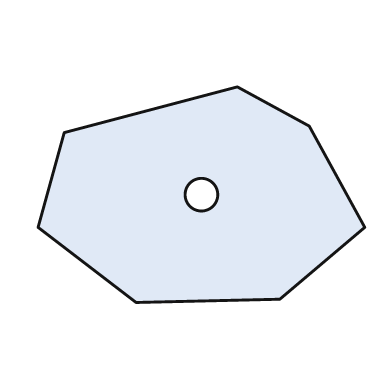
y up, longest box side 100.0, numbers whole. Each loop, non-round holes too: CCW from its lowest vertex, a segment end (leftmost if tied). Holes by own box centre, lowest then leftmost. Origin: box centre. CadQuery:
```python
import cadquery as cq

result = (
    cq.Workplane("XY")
    .moveTo(-20.0, -33.0)
    .lineTo(24.0, -32.0)
    .lineTo(50.0, -10.0)
    .lineTo(33.0, 21.0)
    .lineTo(11.0, 33.0)
    .lineTo(-42.0, 19.0)
    .lineTo(-50.0, -10.0)
    .close()
    .moveTo(0.0, 0.0)
    .circle(5.0)
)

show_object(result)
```